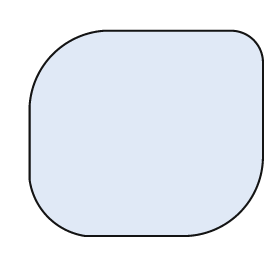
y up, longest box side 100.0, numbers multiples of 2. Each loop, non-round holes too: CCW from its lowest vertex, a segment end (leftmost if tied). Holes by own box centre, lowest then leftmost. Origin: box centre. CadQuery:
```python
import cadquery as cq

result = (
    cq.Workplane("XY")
    .moveTo(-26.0, -44.0)
    .lineTo(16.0, -44.0)
    .threePointArc((40.0, -34.0), (50.0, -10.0))
    .lineTo(50.0, 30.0)
    .threePointArc((46.0, 40.0), (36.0, 44.0))
    .lineTo(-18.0, 44.0)
    .threePointArc((-40.0, 34.0), (-50.0, 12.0))
    .lineTo(-50.0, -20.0)
    .threePointArc((-42.0, -36.0), (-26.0, -44.0))
    .close()
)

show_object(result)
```